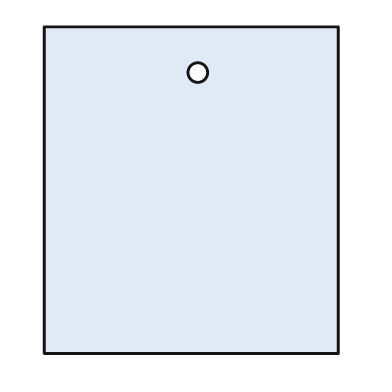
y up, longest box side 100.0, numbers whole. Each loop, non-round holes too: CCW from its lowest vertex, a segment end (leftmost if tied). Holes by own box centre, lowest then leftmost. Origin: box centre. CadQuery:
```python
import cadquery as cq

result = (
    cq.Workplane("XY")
    .moveTo(-45.0, -50.0)
    .lineTo(45.0, -50.0)
    .lineTo(45.0, 50.0)
    .lineTo(-45.0, 50.0)
    .close()
    .moveTo(2.0, 36.0)
    .circle(3.0)
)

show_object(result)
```